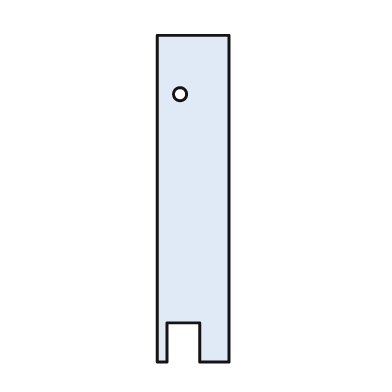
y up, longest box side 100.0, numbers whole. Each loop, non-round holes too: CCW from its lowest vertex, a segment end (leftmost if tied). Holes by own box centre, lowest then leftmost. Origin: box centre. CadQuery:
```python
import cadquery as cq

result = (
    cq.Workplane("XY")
    .moveTo(-11.0, -50.0)
    .lineTo(-8.0, -50.0)
    .lineTo(-8.0, -38.0)
    .lineTo(2.0, -38.0)
    .lineTo(2.0, -50.0)
    .lineTo(11.0, -50.0)
    .lineTo(11.0, 50.0)
    .lineTo(-11.0, 50.0)
    .close()
    .moveTo(-4.0, 32.0)
    .circle(2.0)
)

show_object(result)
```